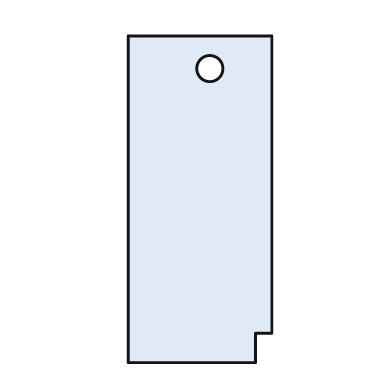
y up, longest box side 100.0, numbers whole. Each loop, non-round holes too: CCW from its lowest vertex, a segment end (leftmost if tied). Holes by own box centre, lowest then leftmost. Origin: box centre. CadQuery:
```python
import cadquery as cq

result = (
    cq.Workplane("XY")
    .moveTo(-22.0, -50.0)
    .lineTo(17.0, -50.0)
    .lineTo(17.0, -41.0)
    .lineTo(22.0, -41.0)
    .lineTo(22.0, 50.0)
    .lineTo(-22.0, 50.0)
    .close()
    .moveTo(3.0, 40.0)
    .circle(4.0)
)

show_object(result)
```